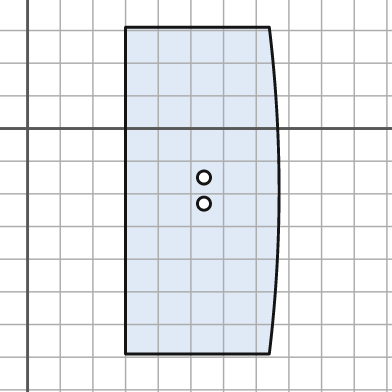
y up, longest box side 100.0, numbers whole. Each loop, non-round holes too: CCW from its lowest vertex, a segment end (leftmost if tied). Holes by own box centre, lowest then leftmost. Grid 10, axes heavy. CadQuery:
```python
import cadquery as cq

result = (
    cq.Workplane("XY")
    .moveTo(30.0, -69.0)
    .lineTo(74.0, -69.0)
    .threePointArc((77.0, -19.0), (74.0, 31.0))
    .lineTo(30.0, 31.0)
    .close()
    .moveTo(54.0, -23.0)
    .circle(2.0)
    .moveTo(54.0, -15.0)
    .circle(2.0)
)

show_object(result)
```